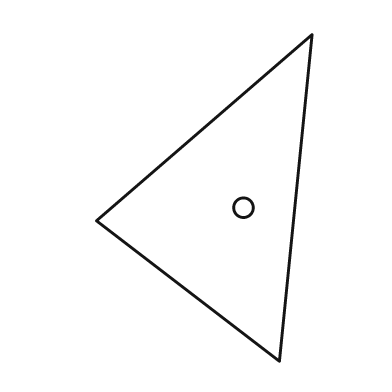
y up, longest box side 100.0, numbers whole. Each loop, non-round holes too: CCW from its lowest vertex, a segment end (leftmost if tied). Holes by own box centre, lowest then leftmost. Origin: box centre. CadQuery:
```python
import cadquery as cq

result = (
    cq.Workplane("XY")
    .moveTo(23.0, -50.0)
    .lineTo(33.0, 50.0)
    .lineTo(-33.0, -7.0)
    .close()
    .moveTo(12.0, -3.0)
    .circle(3.0)
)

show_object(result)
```